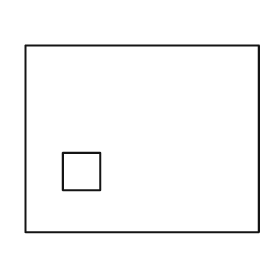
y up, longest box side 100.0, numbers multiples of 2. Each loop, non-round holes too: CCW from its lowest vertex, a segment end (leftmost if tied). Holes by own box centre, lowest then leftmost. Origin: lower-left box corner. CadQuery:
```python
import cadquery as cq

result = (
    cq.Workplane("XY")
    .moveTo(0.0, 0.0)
    .lineTo(100.0, 0.0)
    .lineTo(100.0, 80.0)
    .lineTo(0.0, 80.0)
    .close()
    .moveTo(16.0, 18.0)
    .lineTo(32.0, 18.0)
    .lineTo(32.0, 34.0)
    .lineTo(16.0, 34.0)
    .close()
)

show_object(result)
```